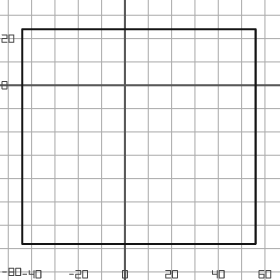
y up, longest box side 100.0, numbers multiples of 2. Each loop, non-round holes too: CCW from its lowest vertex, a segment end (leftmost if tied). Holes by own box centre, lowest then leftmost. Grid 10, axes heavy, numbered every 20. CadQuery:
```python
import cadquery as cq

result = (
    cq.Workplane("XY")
    .moveTo(-44.0, -68.0)
    .lineTo(56.0, -68.0)
    .lineTo(56.0, 24.0)
    .lineTo(-44.0, 24.0)
    .close()
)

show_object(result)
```